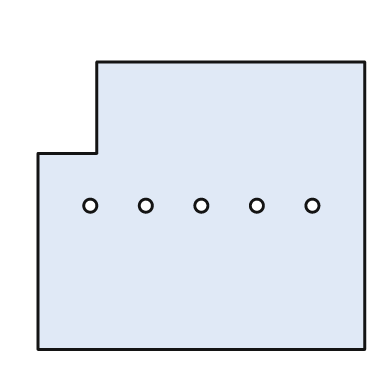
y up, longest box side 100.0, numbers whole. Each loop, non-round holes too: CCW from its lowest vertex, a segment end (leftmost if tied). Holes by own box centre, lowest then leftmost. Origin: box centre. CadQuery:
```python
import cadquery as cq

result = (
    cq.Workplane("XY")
    .moveTo(-50.0, -44.0)
    .lineTo(50.0, -44.0)
    .lineTo(50.0, 44.0)
    .lineTo(-32.0, 44.0)
    .lineTo(-32.0, 16.0)
    .lineTo(-50.0, 16.0)
    .close()
    .moveTo(-34.0, 0.0)
    .circle(2.0)
    .moveTo(-17.0, 0.0)
    .circle(2.0)
    .moveTo(0.0, 0.0)
    .circle(2.0)
    .moveTo(17.0, 0.0)
    .circle(2.0)
    .moveTo(34.0, 0.0)
    .circle(2.0)
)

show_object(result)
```